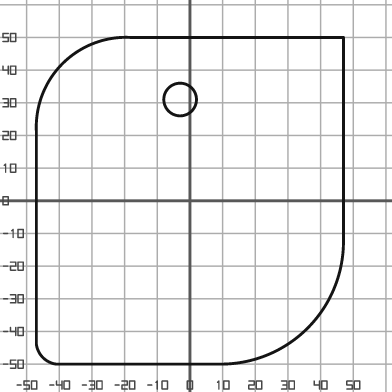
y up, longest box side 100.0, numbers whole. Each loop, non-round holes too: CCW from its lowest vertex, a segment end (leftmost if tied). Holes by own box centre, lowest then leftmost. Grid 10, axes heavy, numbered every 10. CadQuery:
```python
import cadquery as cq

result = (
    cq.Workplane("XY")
    .moveTo(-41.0, -50.0)
    .lineTo(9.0, -50.0)
    .threePointArc((36.0, -39.0), (47.0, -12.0))
    .lineTo(47.0, 50.0)
    .lineTo(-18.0, 50.0)
    .threePointArc((-39.0, 42.0), (-47.0, 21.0))
    .lineTo(-47.0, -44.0)
    .threePointArc((-45.0, -48.0), (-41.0, -50.0))
    .close()
    .moveTo(-3.0, 31.0)
    .circle(5.0)
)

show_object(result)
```